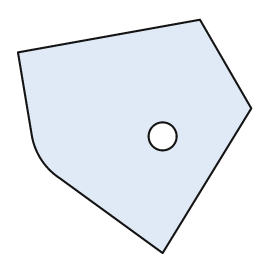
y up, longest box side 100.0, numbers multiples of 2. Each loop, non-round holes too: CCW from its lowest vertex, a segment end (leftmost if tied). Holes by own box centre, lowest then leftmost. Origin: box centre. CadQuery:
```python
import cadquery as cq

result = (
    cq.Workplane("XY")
    .moveTo(12.0, -50.0)
    .lineTo(50.0, 12.0)
    .lineTo(28.0, 50.0)
    .lineTo(-50.0, 36.0)
    .lineTo(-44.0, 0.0)
    .threePointArc((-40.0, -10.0), (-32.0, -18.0))
    .close()
    .moveTo(12.0, 0.0)
    .circle(6.0)
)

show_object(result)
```